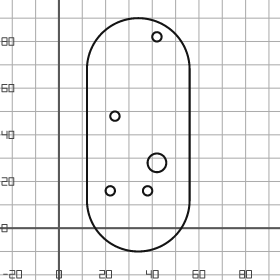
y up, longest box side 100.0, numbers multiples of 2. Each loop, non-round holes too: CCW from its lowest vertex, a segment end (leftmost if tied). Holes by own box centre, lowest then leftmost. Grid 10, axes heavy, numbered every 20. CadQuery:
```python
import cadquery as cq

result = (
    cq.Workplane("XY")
    .moveTo(12.0, 12.0)
    .threePointArc((34.0, -10.0), (56.0, 12.0))
    .lineTo(56.0, 68.0)
    .threePointArc((34.0, 90.0), (12.0, 68.0))
    .close()
    .moveTo(22.0, 16.0)
    .circle(2.0)
    .moveTo(38.0, 16.0)
    .circle(2.0)
    .moveTo(42.0, 28.0)
    .circle(4.0)
    .moveTo(24.0, 48.0)
    .circle(2.0)
    .moveTo(42.0, 82.0)
    .circle(2.0)
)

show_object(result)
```